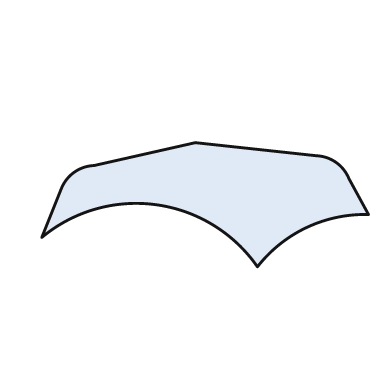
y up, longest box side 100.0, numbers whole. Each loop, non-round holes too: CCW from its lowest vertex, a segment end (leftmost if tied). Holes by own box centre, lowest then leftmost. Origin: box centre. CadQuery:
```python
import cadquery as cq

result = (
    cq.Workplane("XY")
    .moveTo(16.0, -19.0)
    .threePointArc((31.0, -7.0), (50.0, -3.0))
    .lineTo(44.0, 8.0)
    .threePointArc((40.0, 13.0), (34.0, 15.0))
    .lineTo(-3.0, 19.0)
    .lineTo(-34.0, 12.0)
    .threePointArc((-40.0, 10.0), (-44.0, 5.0))
    .lineTo(-50.0, -10.0)
    .threePointArc((-15.0, 0.0), (16.0, -19.0))
    .close()
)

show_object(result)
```